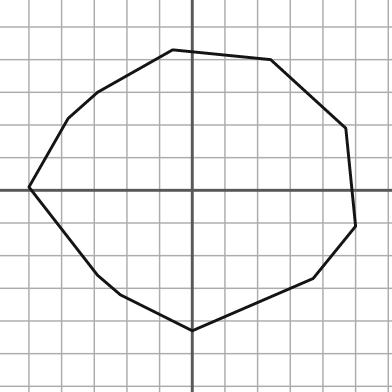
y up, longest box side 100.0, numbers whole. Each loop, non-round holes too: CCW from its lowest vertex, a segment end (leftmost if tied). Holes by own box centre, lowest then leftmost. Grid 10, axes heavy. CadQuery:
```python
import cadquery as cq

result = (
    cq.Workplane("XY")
    .moveTo(0.0, -43.0)
    .lineTo(37.0, -27.0)
    .lineTo(50.0, -11.0)
    .lineTo(47.0, 19.0)
    .lineTo(24.0, 40.0)
    .lineTo(-6.0, 43.0)
    .lineTo(-29.0, 30.0)
    .lineTo(-38.0, 22.0)
    .lineTo(-50.0, 1.0)
    .lineTo(-29.0, -26.0)
    .lineTo(-22.0, -32.0)
    .close()
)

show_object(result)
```